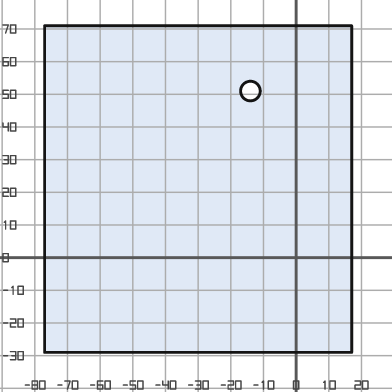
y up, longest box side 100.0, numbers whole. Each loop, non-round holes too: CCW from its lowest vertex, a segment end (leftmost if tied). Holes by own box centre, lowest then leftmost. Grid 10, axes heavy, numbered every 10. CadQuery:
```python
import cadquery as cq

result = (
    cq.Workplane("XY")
    .moveTo(-77.0, -29.0)
    .lineTo(17.0, -29.0)
    .lineTo(17.0, 71.0)
    .lineTo(-77.0, 71.0)
    .close()
    .moveTo(-14.0, 51.0)
    .circle(3.0)
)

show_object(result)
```